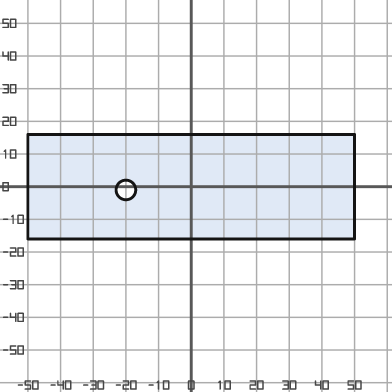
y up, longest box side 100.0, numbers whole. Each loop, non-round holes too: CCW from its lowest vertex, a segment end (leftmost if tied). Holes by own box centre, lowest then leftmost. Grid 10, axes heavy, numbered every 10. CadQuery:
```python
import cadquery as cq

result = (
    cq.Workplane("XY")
    .moveTo(-50.0, -16.0)
    .lineTo(50.0, -16.0)
    .lineTo(50.0, 16.0)
    .lineTo(-50.0, 16.0)
    .close()
    .moveTo(-20.0, -1.0)
    .circle(3.0)
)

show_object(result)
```